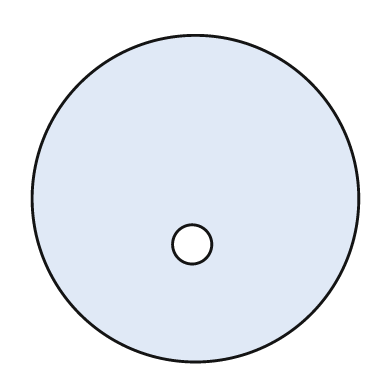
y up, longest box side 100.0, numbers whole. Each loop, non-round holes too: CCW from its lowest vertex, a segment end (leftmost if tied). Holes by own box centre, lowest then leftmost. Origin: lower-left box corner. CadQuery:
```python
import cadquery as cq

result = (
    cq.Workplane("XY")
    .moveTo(50.0, 50.0)
    .circle(50.0)
    .moveTo(49.0, 36.0)
    .circle(6.0)
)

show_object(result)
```